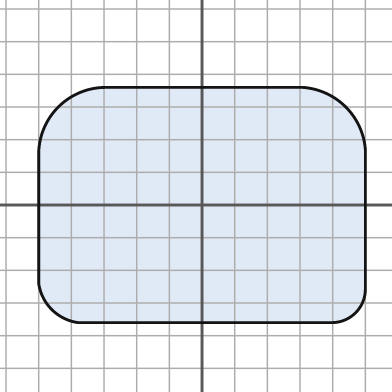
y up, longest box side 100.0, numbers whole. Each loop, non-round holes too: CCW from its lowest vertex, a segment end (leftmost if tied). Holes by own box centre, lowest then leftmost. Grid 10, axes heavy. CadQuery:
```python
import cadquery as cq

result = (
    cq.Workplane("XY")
    .moveTo(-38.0, -36.0)
    .lineTo(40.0, -36.0)
    .threePointArc((47.0, -33.0), (50.0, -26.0))
    .lineTo(50.0, 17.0)
    .threePointArc((44.0, 30.0), (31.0, 36.0))
    .lineTo(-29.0, 36.0)
    .threePointArc((-44.0, 30.0), (-50.0, 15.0))
    .lineTo(-50.0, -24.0)
    .threePointArc((-46.0, -32.0), (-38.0, -36.0))
    .close()
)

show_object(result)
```